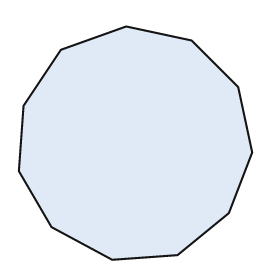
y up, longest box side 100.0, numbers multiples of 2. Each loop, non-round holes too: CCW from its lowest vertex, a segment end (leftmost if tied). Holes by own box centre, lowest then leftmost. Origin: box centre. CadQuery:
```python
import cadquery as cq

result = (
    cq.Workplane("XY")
    .moveTo(-10.0, -50.0)
    .lineTo(18.0, -48.0)
    .lineTo(40.0, -30.0)
    .lineTo(50.0, -4.0)
    .lineTo(44.0, 24.0)
    .lineTo(24.0, 44.0)
    .lineTo(-4.0, 50.0)
    .lineTo(-32.0, 40.0)
    .lineTo(-48.0, 16.0)
    .lineTo(-50.0, -12.0)
    .lineTo(-36.0, -36.0)
    .close()
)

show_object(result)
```